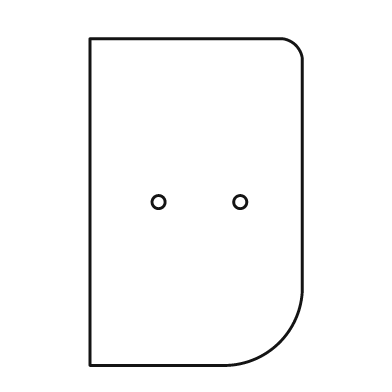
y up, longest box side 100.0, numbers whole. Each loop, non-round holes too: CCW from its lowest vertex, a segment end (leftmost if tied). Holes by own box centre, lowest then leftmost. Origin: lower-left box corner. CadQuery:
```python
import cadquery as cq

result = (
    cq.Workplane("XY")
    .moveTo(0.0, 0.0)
    .lineTo(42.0, 0.0)
    .threePointArc((58.0, 7.0), (65.0, 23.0))
    .lineTo(65.0, 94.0)
    .threePointArc((63.0, 98.0), (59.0, 100.0))
    .lineTo(0.0, 100.0)
    .close()
    .moveTo(21.0, 50.0)
    .circle(2.0)
    .moveTo(46.0, 50.0)
    .circle(2.0)
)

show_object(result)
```